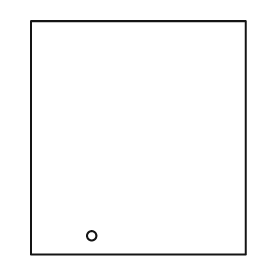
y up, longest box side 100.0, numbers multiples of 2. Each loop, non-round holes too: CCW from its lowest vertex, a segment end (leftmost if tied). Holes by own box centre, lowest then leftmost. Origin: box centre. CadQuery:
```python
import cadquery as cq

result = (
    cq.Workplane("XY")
    .moveTo(-46.0, -50.0)
    .lineTo(46.0, -50.0)
    .lineTo(46.0, 50.0)
    .lineTo(-46.0, 50.0)
    .close()
    .moveTo(-20.0, -42.0)
    .circle(2.0)
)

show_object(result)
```